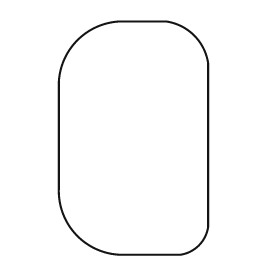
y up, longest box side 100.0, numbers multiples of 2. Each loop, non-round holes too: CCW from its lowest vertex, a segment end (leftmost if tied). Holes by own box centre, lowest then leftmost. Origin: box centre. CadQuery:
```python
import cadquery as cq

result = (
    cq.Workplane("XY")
    .moveTo(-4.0, -50.0)
    .lineTo(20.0, -50.0)
    .threePointArc((28.0, -46.0), (32.0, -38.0))
    .lineTo(32.0, 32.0)
    .threePointArc((26.0, 44.0), (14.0, 50.0))
    .lineTo(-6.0, 50.0)
    .threePointArc((-24.0, 42.0), (-32.0, 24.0))
    .lineTo(-32.0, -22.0)
    .threePointArc((-24.0, -42.0), (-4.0, -50.0))
    .close()
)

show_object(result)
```